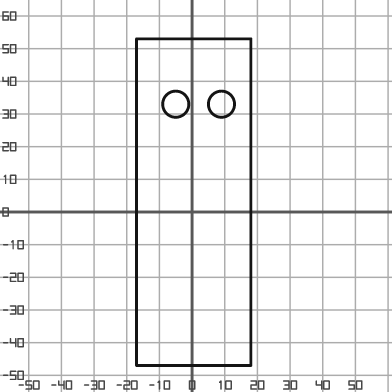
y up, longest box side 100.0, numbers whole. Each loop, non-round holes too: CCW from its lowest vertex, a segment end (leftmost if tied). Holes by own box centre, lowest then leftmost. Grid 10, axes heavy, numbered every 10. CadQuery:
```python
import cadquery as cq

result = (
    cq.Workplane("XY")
    .moveTo(-17.0, -47.0)
    .lineTo(18.0, -47.0)
    .lineTo(18.0, 53.0)
    .lineTo(-17.0, 53.0)
    .close()
    .moveTo(-5.0, 33.0)
    .circle(4.0)
    .moveTo(9.0, 33.0)
    .circle(4.0)
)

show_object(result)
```